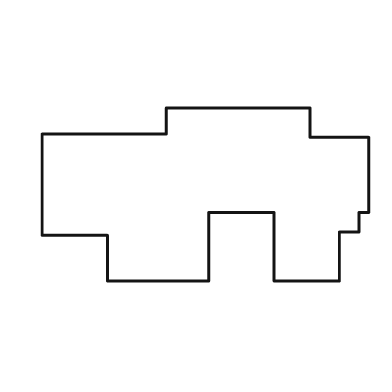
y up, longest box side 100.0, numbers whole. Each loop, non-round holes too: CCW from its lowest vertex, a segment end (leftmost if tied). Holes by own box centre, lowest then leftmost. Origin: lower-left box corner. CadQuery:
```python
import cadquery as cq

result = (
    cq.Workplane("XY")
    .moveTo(20.0, 0.0)
    .lineTo(51.0, 0.0)
    .lineTo(51.0, 21.0)
    .lineTo(71.0, 21.0)
    .lineTo(71.0, 0.0)
    .lineTo(91.0, 0.0)
    .lineTo(91.0, 15.0)
    .lineTo(97.0, 15.0)
    .lineTo(97.0, 21.0)
    .lineTo(100.0, 21.0)
    .lineTo(100.0, 44.0)
    .lineTo(82.0, 44.0)
    .lineTo(82.0, 53.0)
    .lineTo(38.0, 53.0)
    .lineTo(38.0, 45.0)
    .lineTo(0.0, 45.0)
    .lineTo(0.0, 14.0)
    .lineTo(20.0, 14.0)
    .close()
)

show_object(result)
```